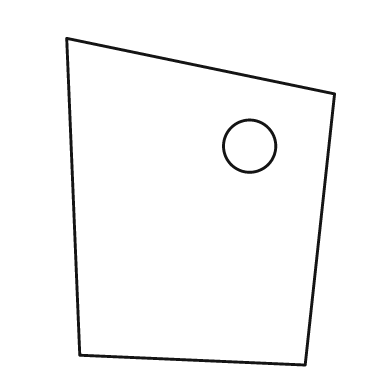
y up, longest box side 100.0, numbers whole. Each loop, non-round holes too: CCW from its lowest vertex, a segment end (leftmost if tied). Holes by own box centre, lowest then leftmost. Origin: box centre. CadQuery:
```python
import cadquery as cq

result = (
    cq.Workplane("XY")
    .moveTo(32.0, -50.0)
    .lineTo(41.0, 33.0)
    .lineTo(-41.0, 50.0)
    .lineTo(-37.0, -47.0)
    .close()
    .moveTo(15.0, 17.0)
    .circle(8.0)
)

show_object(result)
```